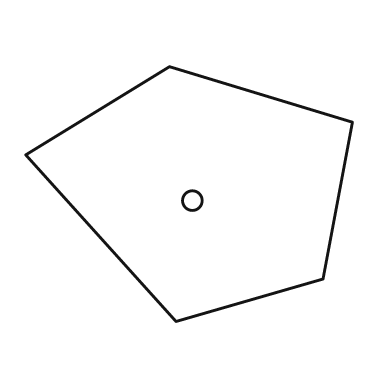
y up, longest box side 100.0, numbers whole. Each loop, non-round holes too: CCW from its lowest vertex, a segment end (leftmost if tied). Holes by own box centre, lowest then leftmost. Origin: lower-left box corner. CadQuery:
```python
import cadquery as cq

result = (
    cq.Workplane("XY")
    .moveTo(46.0, 0.0)
    .lineTo(91.0, 13.0)
    .lineTo(100.0, 61.0)
    .lineTo(44.0, 78.0)
    .lineTo(0.0, 51.0)
    .close()
    .moveTo(51.0, 37.0)
    .circle(3.0)
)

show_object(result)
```